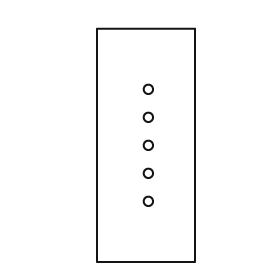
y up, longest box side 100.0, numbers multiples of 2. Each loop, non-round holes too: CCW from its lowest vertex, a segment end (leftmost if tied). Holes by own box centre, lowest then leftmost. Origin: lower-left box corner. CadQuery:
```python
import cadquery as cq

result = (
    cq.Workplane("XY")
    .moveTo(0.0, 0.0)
    .lineTo(42.0, 0.0)
    .lineTo(42.0, 100.0)
    .lineTo(0.0, 100.0)
    .close()
    .moveTo(22.0, 26.0)
    .circle(2.0)
    .moveTo(22.0, 38.0)
    .circle(2.0)
    .moveTo(22.0, 50.0)
    .circle(2.0)
    .moveTo(22.0, 62.0)
    .circle(2.0)
    .moveTo(22.0, 74.0)
    .circle(2.0)
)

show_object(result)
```